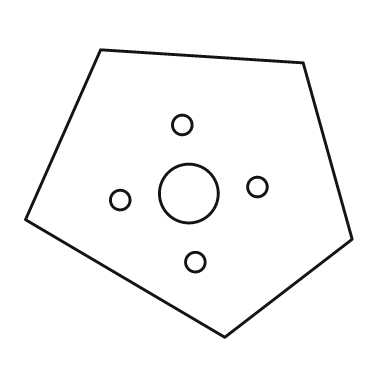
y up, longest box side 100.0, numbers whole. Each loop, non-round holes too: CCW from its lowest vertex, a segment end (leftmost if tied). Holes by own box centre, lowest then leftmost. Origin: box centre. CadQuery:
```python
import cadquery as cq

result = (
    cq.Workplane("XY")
    .moveTo(11.0, -44.0)
    .lineTo(50.0, -14.0)
    .lineTo(35.0, 40.0)
    .lineTo(-27.0, 44.0)
    .lineTo(-50.0, -8.0)
    .close()
    .moveTo(2.0, -21.0)
    .circle(3.0)
    .moveTo(-21.0, -2.0)
    .circle(3.0)
    .moveTo(0.0, 0.0)
    .circle(9.0)
    .moveTo(21.0, 2.0)
    .circle(3.0)
    .moveTo(-2.0, 21.0)
    .circle(3.0)
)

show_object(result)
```